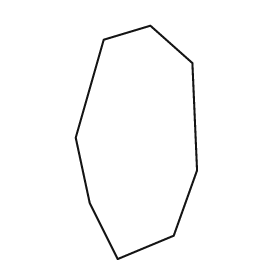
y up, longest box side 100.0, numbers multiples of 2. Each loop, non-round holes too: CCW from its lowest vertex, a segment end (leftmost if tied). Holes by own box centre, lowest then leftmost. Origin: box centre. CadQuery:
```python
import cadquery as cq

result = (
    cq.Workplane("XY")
    .moveTo(-8.0, -50.0)
    .lineTo(16.0, -40.0)
    .lineTo(26.0, -12.0)
    .lineTo(24.0, 34.0)
    .lineTo(6.0, 50.0)
    .lineTo(-14.0, 44.0)
    .lineTo(-26.0, 2.0)
    .lineTo(-20.0, -26.0)
    .close()
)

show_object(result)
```